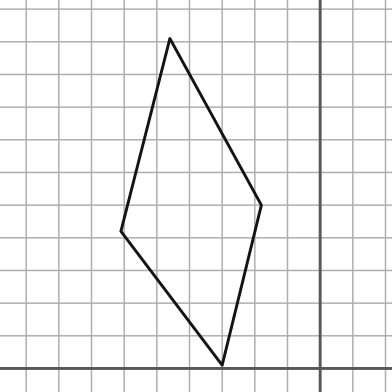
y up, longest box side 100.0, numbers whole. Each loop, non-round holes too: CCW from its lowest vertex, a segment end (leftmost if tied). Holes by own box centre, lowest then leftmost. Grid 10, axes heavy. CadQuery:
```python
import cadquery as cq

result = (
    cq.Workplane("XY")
    .moveTo(-30.0, 1.0)
    .lineTo(-18.0, 50.0)
    .lineTo(-46.0, 101.0)
    .lineTo(-61.0, 42.0)
    .close()
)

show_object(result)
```